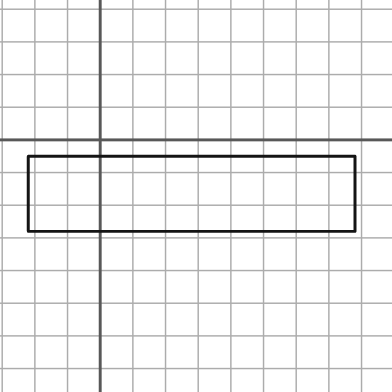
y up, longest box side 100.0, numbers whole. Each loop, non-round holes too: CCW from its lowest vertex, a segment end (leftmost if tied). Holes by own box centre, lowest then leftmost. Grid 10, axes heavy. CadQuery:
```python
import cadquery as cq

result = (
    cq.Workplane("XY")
    .moveTo(-22.0, -28.0)
    .lineTo(78.0, -28.0)
    .lineTo(78.0, -5.0)
    .lineTo(-22.0, -5.0)
    .close()
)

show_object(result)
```